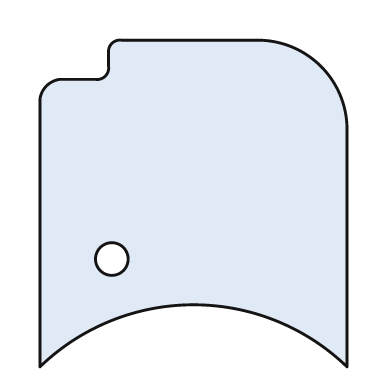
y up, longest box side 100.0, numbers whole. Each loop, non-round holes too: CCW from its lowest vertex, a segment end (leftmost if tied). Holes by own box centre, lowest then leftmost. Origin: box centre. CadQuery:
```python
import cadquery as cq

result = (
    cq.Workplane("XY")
    .moveTo(-47.0, -50.0)
    .threePointArc((0.0, -31.0), (47.0, -50.0))
    .lineTo(47.0, 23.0)
    .threePointArc((39.0, 42.0), (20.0, 50.0))
    .lineTo(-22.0, 50.0)
    .threePointArc((-25.0, 49.0), (-26.0, 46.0))
    .lineTo(-26.0, 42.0)
    .threePointArc((-27.0, 39.0), (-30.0, 38.0))
    .lineTo(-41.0, 38.0)
    .threePointArc((-45.0, 36.0), (-47.0, 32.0))
    .close()
    .moveTo(-25.0, -17.0)
    .circle(5.0)
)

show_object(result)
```